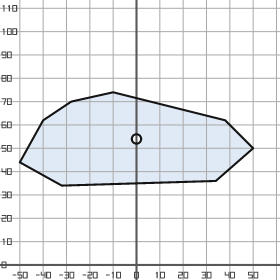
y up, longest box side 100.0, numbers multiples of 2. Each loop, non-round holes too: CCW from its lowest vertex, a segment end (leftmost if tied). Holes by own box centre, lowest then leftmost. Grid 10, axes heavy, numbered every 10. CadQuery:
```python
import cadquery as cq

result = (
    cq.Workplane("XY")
    .moveTo(-32.0, 34.0)
    .lineTo(34.0, 36.0)
    .lineTo(50.0, 50.0)
    .lineTo(38.0, 62.0)
    .lineTo(-10.0, 74.0)
    .lineTo(-28.0, 70.0)
    .lineTo(-40.0, 62.0)
    .lineTo(-50.0, 44.0)
    .close()
    .moveTo(0.0, 54.0)
    .circle(2.0)
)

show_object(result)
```